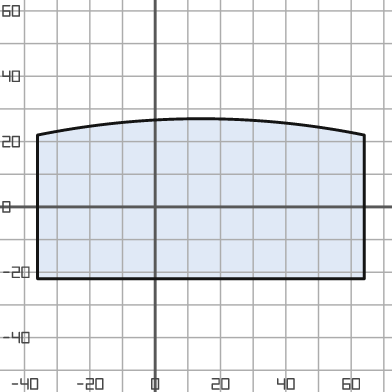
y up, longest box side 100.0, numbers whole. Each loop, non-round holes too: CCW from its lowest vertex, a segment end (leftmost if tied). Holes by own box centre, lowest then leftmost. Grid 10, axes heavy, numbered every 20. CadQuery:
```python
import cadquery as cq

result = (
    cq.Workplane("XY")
    .moveTo(-36.0, -22.0)
    .lineTo(64.0, -22.0)
    .lineTo(64.0, 22.0)
    .threePointArc((14.0, 27.0), (-36.0, 22.0))
    .close()
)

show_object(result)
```